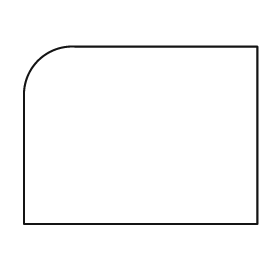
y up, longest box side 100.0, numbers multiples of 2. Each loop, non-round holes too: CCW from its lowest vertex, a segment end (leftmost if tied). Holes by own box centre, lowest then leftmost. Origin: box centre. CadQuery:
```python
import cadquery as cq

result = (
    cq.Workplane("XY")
    .moveTo(-50.0, -38.0)
    .lineTo(50.0, -38.0)
    .lineTo(50.0, 38.0)
    .lineTo(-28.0, 38.0)
    .threePointArc((-44.0, 32.0), (-50.0, 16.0))
    .close()
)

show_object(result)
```